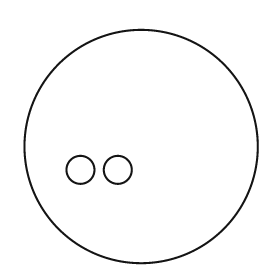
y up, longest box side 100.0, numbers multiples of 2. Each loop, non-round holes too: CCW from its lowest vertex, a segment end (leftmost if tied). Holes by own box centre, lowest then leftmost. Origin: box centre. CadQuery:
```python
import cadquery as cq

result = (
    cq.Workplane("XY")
    .moveTo(0.0, 0.0)
    .circle(50.0)
    .moveTo(-26.0, -10.0)
    .circle(6.0)
    .moveTo(-10.0, -10.0)
    .circle(6.0)
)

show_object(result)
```